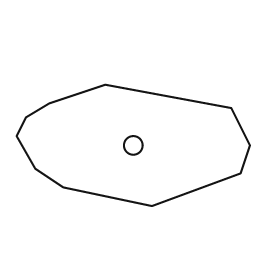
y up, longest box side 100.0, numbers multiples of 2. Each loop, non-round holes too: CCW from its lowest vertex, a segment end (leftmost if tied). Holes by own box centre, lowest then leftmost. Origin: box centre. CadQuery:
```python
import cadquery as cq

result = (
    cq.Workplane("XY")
    .moveTo(8.0, -26.0)
    .lineTo(46.0, -12.0)
    .lineTo(50.0, 0.0)
    .lineTo(42.0, 16.0)
    .lineTo(-12.0, 26.0)
    .lineTo(-36.0, 18.0)
    .lineTo(-46.0, 12.0)
    .lineTo(-50.0, 4.0)
    .lineTo(-42.0, -10.0)
    .lineTo(-30.0, -18.0)
    .close()
    .moveTo(0.0, 0.0)
    .circle(4.0)
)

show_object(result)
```